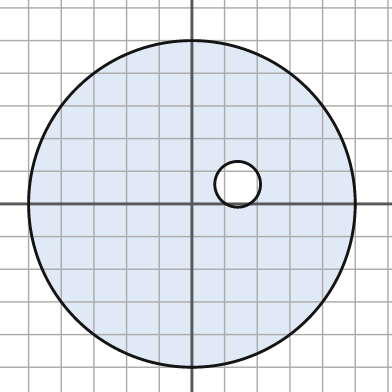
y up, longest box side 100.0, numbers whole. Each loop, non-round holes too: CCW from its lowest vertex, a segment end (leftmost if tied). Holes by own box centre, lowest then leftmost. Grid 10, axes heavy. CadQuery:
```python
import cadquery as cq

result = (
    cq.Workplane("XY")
    .moveTo(0.0, 0.0)
    .circle(50.0)
    .moveTo(14.0, 6.0)
    .circle(7.0)
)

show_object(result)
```